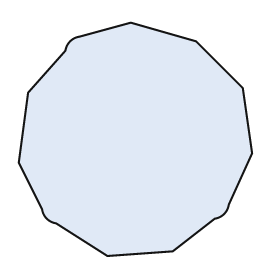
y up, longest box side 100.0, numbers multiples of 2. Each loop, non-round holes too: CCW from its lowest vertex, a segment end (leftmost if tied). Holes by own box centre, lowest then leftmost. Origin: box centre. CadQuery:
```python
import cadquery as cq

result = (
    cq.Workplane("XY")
    .moveTo(-12.0, -50.0)
    .lineTo(16.0, -48.0)
    .lineTo(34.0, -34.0)
    .threePointArc((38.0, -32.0), (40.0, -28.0))
    .lineTo(50.0, -6.0)
    .lineTo(46.0, 22.0)
    .lineTo(26.0, 42.0)
    .lineTo(-2.0, 50.0)
    .lineTo(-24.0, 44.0)
    .threePointArc((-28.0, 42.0), (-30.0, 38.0))
    .lineTo(-46.0, 20.0)
    .lineTo(-50.0, -10.0)
    .lineTo(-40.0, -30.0)
    .threePointArc((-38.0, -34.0), (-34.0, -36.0))
    .close()
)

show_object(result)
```